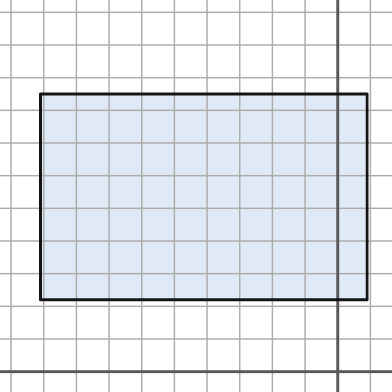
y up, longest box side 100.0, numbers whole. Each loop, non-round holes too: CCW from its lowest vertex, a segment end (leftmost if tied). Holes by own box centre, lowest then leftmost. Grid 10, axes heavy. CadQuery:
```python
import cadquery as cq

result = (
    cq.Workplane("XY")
    .moveTo(-91.0, 22.0)
    .lineTo(9.0, 22.0)
    .lineTo(9.0, 85.0)
    .lineTo(-91.0, 85.0)
    .close()
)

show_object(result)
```